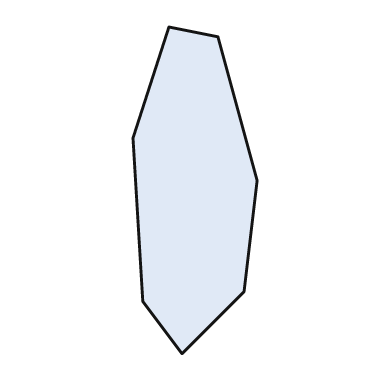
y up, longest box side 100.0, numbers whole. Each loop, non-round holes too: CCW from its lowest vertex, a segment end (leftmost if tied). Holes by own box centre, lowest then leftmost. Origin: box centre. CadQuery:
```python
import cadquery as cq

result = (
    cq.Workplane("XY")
    .moveTo(-4.0, -50.0)
    .lineTo(15.0, -31.0)
    .lineTo(19.0, 3.0)
    .lineTo(7.0, 47.0)
    .lineTo(-8.0, 50.0)
    .lineTo(-19.0, 16.0)
    .lineTo(-16.0, -34.0)
    .close()
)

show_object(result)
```